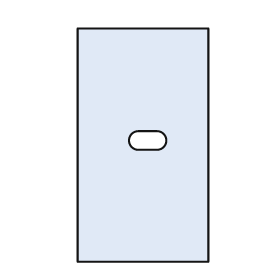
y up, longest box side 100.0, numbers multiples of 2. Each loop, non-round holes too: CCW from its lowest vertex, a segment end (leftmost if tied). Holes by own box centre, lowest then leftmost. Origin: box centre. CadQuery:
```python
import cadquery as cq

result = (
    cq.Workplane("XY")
    .moveTo(-28.0, -50.0)
    .lineTo(28.0, -50.0)
    .lineTo(28.0, 50.0)
    .lineTo(-28.0, 50.0)
    .close()
    .moveTo(-2.0, -2.0)
    .lineTo(6.0, -2.0)
    .threePointArc((10.0, 2.0), (6.0, 6.0))
    .lineTo(-2.0, 6.0)
    .threePointArc((-6.0, 2.0), (-2.0, -2.0))
    .close()
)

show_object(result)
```